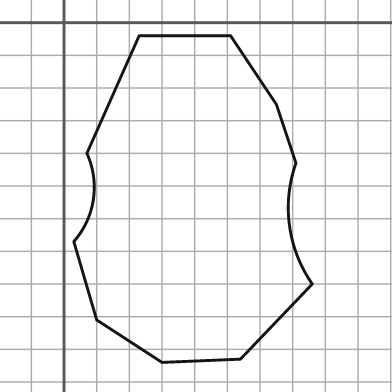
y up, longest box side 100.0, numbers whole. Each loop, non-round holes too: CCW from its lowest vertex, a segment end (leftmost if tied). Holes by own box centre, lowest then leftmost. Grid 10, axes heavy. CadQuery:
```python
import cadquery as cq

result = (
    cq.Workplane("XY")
    .moveTo(30.0, -104.0)
    .lineTo(54.0, -103.0)
    .lineTo(76.0, -80.0)
    .threePointArc((69.0, -62.0), (71.0, -43.0))
    .lineTo(65.0, -25.0)
    .lineTo(51.0, -4.0)
    .lineTo(23.0, -4.0)
    .lineTo(7.0, -40.0)
    .threePointArc((9.0, -54.0), (3.0, -67.0))
    .lineTo(10.0, -91.0)
    .close()
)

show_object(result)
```